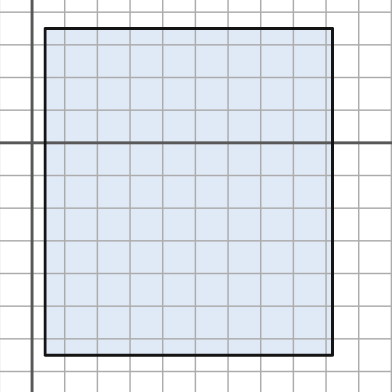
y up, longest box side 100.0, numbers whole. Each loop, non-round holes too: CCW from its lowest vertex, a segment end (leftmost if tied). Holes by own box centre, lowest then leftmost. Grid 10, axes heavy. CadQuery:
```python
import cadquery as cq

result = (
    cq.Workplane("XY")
    .moveTo(4.0, -65.0)
    .lineTo(92.0, -65.0)
    .lineTo(92.0, 35.0)
    .lineTo(4.0, 35.0)
    .close()
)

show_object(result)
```